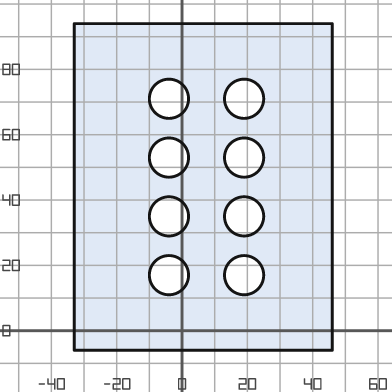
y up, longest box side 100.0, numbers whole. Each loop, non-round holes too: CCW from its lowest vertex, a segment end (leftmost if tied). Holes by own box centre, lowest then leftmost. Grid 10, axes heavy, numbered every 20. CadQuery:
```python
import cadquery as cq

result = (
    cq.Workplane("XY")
    .moveTo(-33.0, -6.0)
    .lineTo(46.0, -6.0)
    .lineTo(46.0, 94.0)
    .lineTo(-33.0, 94.0)
    .close()
    .moveTo(-4.0, 17.0)
    .circle(6.0)
    .moveTo(19.0, 17.0)
    .circle(6.0)
    .moveTo(-4.0, 35.0)
    .circle(6.0)
    .moveTo(19.0, 35.0)
    .circle(6.0)
    .moveTo(-4.0, 53.0)
    .circle(6.0)
    .moveTo(19.0, 53.0)
    .circle(6.0)
    .moveTo(-4.0, 71.0)
    .circle(6.0)
    .moveTo(19.0, 71.0)
    .circle(6.0)
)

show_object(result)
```